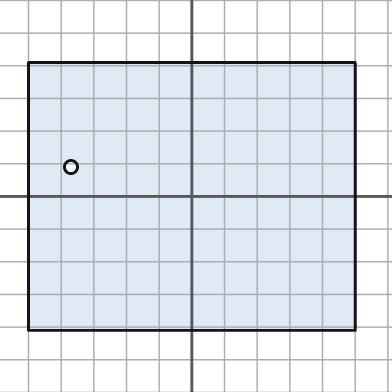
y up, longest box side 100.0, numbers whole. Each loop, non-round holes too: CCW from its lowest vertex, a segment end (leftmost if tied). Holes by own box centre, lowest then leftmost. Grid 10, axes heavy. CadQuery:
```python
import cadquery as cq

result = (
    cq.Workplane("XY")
    .moveTo(-50.0, -41.0)
    .lineTo(50.0, -41.0)
    .lineTo(50.0, 41.0)
    .lineTo(-50.0, 41.0)
    .close()
    .moveTo(-37.0, 9.0)
    .circle(2.0)
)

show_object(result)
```